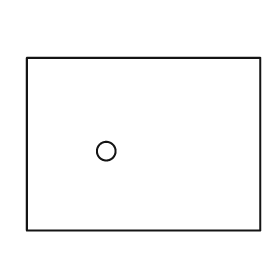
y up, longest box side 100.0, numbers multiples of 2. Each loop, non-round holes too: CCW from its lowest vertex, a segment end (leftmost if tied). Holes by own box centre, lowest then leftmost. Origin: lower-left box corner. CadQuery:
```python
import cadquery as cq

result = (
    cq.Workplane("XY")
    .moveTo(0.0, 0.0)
    .lineTo(100.0, 0.0)
    .lineTo(100.0, 74.0)
    .lineTo(0.0, 74.0)
    .close()
    .moveTo(34.0, 34.0)
    .circle(4.0)
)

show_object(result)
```